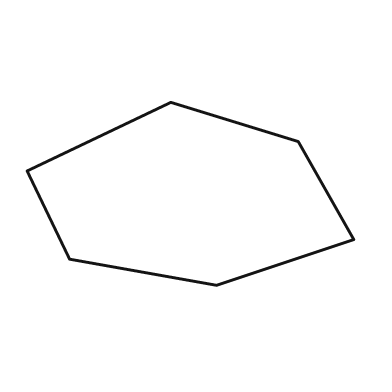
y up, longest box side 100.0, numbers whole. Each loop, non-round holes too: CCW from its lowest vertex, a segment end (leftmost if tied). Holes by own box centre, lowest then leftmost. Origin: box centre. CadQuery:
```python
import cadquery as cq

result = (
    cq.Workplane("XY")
    .moveTo(8.0, -28.0)
    .lineTo(50.0, -14.0)
    .lineTo(33.0, 16.0)
    .lineTo(-6.0, 28.0)
    .lineTo(-50.0, 7.0)
    .lineTo(-37.0, -20.0)
    .close()
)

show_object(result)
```